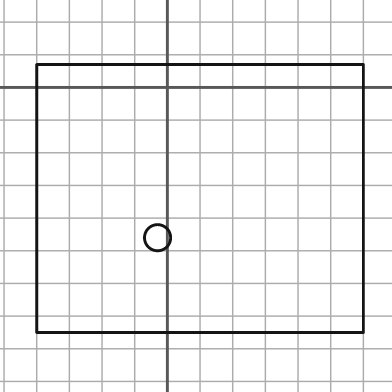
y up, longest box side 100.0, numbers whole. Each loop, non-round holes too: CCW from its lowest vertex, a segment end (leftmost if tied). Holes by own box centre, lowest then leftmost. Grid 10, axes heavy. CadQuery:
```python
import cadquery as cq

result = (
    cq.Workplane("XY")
    .moveTo(-40.0, -75.0)
    .lineTo(60.0, -75.0)
    .lineTo(60.0, 7.0)
    .lineTo(-40.0, 7.0)
    .close()
    .moveTo(-3.0, -46.0)
    .circle(4.0)
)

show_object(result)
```